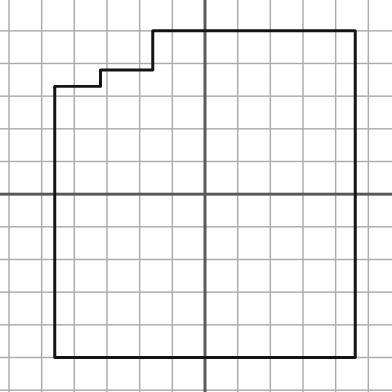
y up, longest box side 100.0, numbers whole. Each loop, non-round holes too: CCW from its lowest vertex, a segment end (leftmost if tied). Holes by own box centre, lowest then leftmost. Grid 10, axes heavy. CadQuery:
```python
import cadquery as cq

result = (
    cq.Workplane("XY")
    .moveTo(-46.0, -50.0)
    .lineTo(46.0, -50.0)
    .lineTo(46.0, 50.0)
    .lineTo(-16.0, 50.0)
    .lineTo(-16.0, 38.0)
    .lineTo(-32.0, 38.0)
    .lineTo(-32.0, 33.0)
    .lineTo(-46.0, 33.0)
    .close()
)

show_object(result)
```